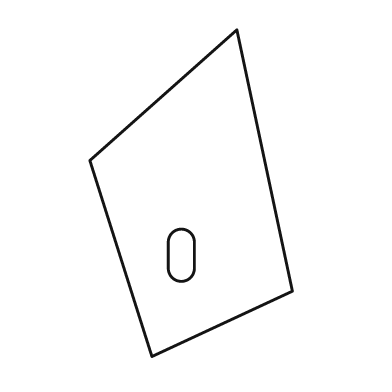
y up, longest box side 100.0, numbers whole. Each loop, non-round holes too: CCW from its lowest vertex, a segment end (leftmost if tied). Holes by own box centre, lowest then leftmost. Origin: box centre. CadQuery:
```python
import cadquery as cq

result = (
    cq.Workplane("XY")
    .moveTo(-12.0, -50.0)
    .lineTo(31.0, -30.0)
    .lineTo(14.0, 50.0)
    .lineTo(-31.0, 10.0)
    .close()
    .moveTo(-7.0, -23.0)
    .threePointArc((-3.0, -27.0), (1.0, -23.0))
    .lineTo(1.0, -15.0)
    .threePointArc((-3.0, -11.0), (-7.0, -15.0))
    .close()
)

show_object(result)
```